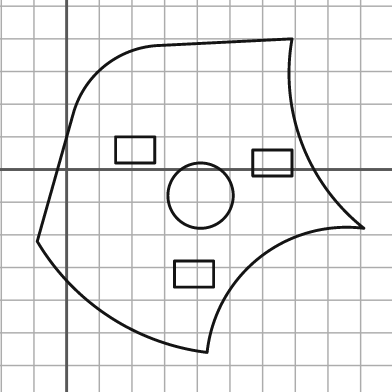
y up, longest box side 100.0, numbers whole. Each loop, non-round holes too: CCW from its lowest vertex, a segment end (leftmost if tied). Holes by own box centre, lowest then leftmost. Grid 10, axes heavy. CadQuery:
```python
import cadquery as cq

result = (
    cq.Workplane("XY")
    .moveTo(43.0, -56.0)
    .threePointArc((59.0, -27.0), (91.0, -18.0))
    .threePointArc((72.0, 8.0), (69.0, 40.0))
    .lineTo(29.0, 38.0)
    .threePointArc((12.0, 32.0), (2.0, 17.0))
    .lineTo(-9.0, -22.0)
    .threePointArc((13.0, -45.0), (43.0, -56.0))
    .close()
    .moveTo(33.0, -36.0)
    .lineTo(45.0, -36.0)
    .lineTo(45.0, -28.0)
    .lineTo(33.0, -28.0)
    .close()
    .moveTo(41.0, -8.0)
    .circle(10.0)
    .moveTo(57.0, -2.0)
    .lineTo(69.0, -2.0)
    .lineTo(69.0, 6.0)
    .lineTo(57.0, 6.0)
    .close()
    .moveTo(15.0, 2.0)
    .lineTo(27.0, 2.0)
    .lineTo(27.0, 10.0)
    .lineTo(15.0, 10.0)
    .close()
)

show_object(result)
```